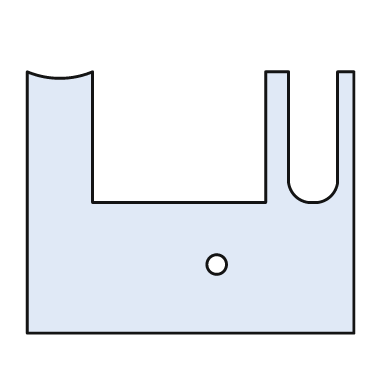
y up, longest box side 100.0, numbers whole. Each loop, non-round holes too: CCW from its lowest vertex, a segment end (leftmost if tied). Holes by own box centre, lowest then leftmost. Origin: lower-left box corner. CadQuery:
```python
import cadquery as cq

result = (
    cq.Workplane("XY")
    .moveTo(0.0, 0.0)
    .lineTo(100.0, 0.0)
    .lineTo(100.0, 80.0)
    .lineTo(95.0, 80.0)
    .lineTo(95.0, 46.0)
    .threePointArc((93.0, 42.0), (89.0, 40.0))
    .lineTo(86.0, 40.0)
    .threePointArc((82.0, 42.0), (80.0, 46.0))
    .lineTo(80.0, 80.0)
    .lineTo(73.0, 80.0)
    .lineTo(73.0, 40.0)
    .lineTo(20.0, 40.0)
    .lineTo(20.0, 80.0)
    .threePointArc((10.0, 78.0), (0.0, 80.0))
    .close()
    .moveTo(58.0, 21.0)
    .circle(3.0)
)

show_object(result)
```